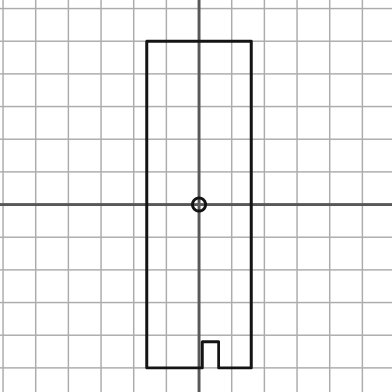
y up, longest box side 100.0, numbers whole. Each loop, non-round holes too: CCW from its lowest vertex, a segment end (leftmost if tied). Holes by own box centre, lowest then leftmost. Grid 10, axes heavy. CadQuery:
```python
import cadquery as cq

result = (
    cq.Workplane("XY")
    .moveTo(-16.0, -50.0)
    .lineTo(1.0, -50.0)
    .lineTo(1.0, -42.0)
    .lineTo(6.0, -42.0)
    .lineTo(6.0, -50.0)
    .lineTo(16.0, -50.0)
    .lineTo(16.0, 50.0)
    .lineTo(-16.0, 50.0)
    .close()
    .moveTo(0.0, 0.0)
    .circle(2.0)
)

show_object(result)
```